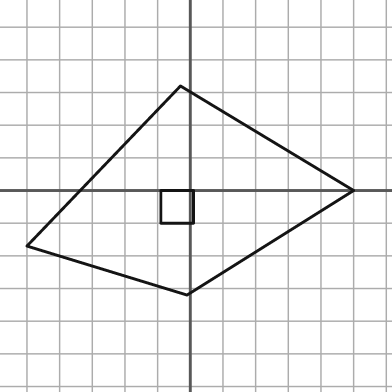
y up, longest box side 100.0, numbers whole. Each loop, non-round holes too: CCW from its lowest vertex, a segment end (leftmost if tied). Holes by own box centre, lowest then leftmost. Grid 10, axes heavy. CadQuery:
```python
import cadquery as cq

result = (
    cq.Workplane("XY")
    .moveTo(-1.0, -32.0)
    .lineTo(50.0, 0.0)
    .lineTo(-3.0, 32.0)
    .lineTo(-50.0, -17.0)
    .close()
    .moveTo(-9.0, -10.0)
    .lineTo(1.0, -10.0)
    .lineTo(1.0, 0.0)
    .lineTo(-9.0, 0.0)
    .close()
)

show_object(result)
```